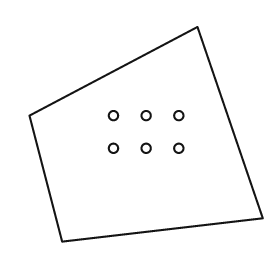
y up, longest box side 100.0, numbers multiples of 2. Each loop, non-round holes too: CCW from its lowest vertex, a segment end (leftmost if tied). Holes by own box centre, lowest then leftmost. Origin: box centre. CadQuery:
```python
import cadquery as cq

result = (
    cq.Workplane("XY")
    .moveTo(-36.0, -46.0)
    .lineTo(50.0, -36.0)
    .lineTo(22.0, 46.0)
    .lineTo(-50.0, 8.0)
    .close()
    .moveTo(-14.0, -6.0)
    .circle(2.0)
    .moveTo(0.0, -6.0)
    .circle(2.0)
    .moveTo(14.0, -6.0)
    .circle(2.0)
    .moveTo(-14.0, 8.0)
    .circle(2.0)
    .moveTo(0.0, 8.0)
    .circle(2.0)
    .moveTo(14.0, 8.0)
    .circle(2.0)
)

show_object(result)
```